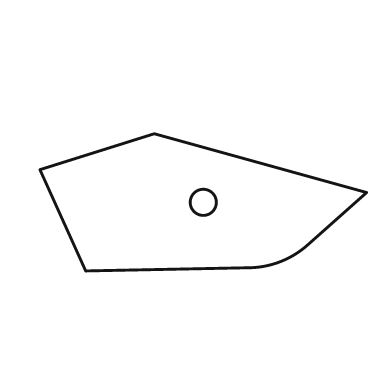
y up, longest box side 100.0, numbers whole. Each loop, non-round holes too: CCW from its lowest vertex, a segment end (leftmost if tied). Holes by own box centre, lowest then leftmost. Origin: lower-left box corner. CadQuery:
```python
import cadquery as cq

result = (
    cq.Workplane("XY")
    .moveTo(14.0, 0.0)
    .lineTo(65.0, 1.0)
    .threePointArc((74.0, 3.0), (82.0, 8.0))
    .lineTo(100.0, 24.0)
    .lineTo(35.0, 42.0)
    .lineTo(0.0, 31.0)
    .close()
    .moveTo(50.0, 21.0)
    .circle(4.0)
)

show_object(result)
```